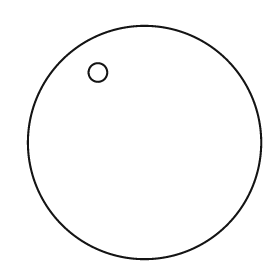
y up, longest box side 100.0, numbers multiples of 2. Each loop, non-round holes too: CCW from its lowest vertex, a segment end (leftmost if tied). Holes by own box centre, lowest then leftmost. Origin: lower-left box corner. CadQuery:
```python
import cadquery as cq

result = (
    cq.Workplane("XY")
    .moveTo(50.0, 50.0)
    .circle(50.0)
    .moveTo(30.0, 80.0)
    .circle(4.0)
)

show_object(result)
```